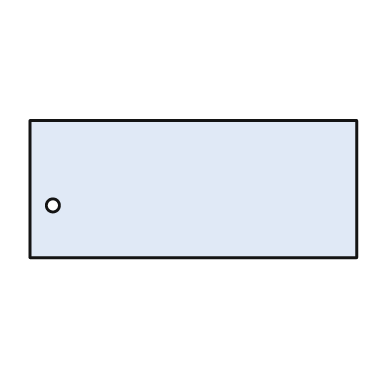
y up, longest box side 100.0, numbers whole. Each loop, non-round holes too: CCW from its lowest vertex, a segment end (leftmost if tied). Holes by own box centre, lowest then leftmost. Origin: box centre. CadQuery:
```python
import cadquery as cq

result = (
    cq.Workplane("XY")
    .moveTo(-50.0, -21.0)
    .lineTo(50.0, -21.0)
    .lineTo(50.0, 21.0)
    .lineTo(-50.0, 21.0)
    .close()
    .moveTo(-43.0, -5.0)
    .circle(2.0)
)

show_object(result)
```